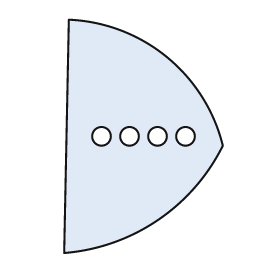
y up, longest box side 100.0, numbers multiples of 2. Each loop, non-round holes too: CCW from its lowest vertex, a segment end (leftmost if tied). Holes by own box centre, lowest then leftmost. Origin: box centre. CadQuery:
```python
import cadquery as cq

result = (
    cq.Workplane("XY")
    .moveTo(-34.0, -50.0)
    .threePointArc((6.0, -36.0), (34.0, -4.0))
    .threePointArc((10.0, 34.0), (-32.0, 50.0))
    .close()
    .moveTo(-18.0, 0.0)
    .circle(4.0)
    .moveTo(-6.0, 0.0)
    .circle(4.0)
    .moveTo(6.0, 0.0)
    .circle(4.0)
    .moveTo(18.0, 0.0)
    .circle(4.0)
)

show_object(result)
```